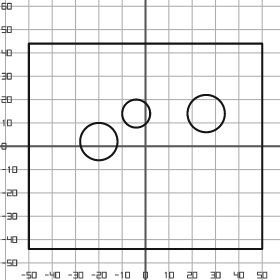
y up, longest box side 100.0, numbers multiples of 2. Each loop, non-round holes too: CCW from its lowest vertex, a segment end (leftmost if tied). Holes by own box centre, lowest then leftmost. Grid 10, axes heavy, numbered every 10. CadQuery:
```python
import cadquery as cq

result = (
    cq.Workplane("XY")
    .moveTo(-50.0, -44.0)
    .lineTo(50.0, -44.0)
    .lineTo(50.0, 44.0)
    .lineTo(-50.0, 44.0)
    .close()
    .moveTo(-20.0, 2.0)
    .circle(8.0)
    .moveTo(-4.0, 14.0)
    .circle(6.0)
    .moveTo(26.0, 14.0)
    .circle(8.0)
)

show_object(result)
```